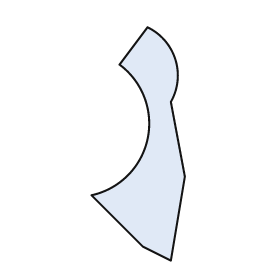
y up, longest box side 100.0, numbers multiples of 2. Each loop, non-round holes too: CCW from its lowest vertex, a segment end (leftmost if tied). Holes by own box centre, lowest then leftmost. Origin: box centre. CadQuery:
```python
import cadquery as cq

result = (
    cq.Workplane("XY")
    .moveTo(14.0, -50.0)
    .lineTo(20.0, -14.0)
    .lineTo(14.0, 18.0)
    .threePointArc((16.0, 36.0), (4.0, 50.0))
    .lineTo(-8.0, 34.0)
    .threePointArc((4.0, 2.0), (-20.0, -22.0))
    .lineTo(2.0, -44.0)
    .close()
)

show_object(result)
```